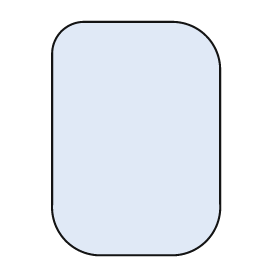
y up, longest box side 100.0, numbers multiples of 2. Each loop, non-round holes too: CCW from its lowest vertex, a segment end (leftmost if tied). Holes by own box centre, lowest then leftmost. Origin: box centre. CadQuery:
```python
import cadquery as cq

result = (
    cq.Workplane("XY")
    .moveTo(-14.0, -50.0)
    .lineTo(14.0, -50.0)
    .threePointArc((30.0, -44.0), (36.0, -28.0))
    .lineTo(36.0, 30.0)
    .threePointArc((30.0, 44.0), (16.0, 50.0))
    .lineTo(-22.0, 50.0)
    .threePointArc((-32.0, 46.0), (-36.0, 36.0))
    .lineTo(-36.0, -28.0)
    .threePointArc((-30.0, -44.0), (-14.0, -50.0))
    .close()
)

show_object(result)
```